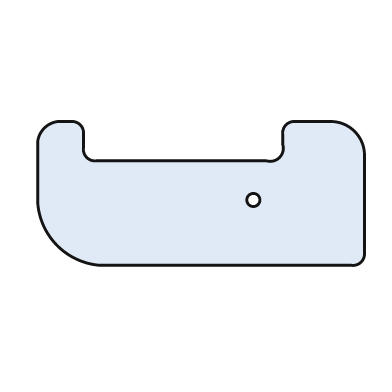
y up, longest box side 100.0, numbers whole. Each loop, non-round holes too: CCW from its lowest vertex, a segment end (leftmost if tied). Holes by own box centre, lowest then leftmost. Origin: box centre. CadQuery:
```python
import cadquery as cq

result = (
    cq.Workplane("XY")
    .moveTo(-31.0, -22.0)
    .lineTo(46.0, -22.0)
    .threePointArc((49.0, -21.0), (50.0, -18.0))
    .lineTo(50.0, 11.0)
    .threePointArc((47.0, 19.0), (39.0, 22.0))
    .lineTo(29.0, 22.0)
    .threePointArc((26.0, 21.0), (25.0, 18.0))
    .lineTo(25.0, 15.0)
    .threePointArc((24.0, 11.0), (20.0, 10.0))
    .lineTo(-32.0, 10.0)
    .threePointArc((-35.0, 11.0), (-36.0, 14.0))
    .lineTo(-36.0, 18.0)
    .threePointArc((-37.0, 21.0), (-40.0, 22.0))
    .lineTo(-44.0, 22.0)
    .threePointArc((-48.0, 20.0), (-50.0, 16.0))
    .lineTo(-50.0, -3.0)
    .threePointArc((-44.0, -16.0), (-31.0, -22.0))
    .close()
    .moveTo(16.0, -2.0)
    .circle(2.0)
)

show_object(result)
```